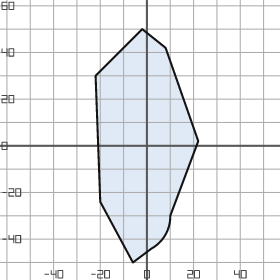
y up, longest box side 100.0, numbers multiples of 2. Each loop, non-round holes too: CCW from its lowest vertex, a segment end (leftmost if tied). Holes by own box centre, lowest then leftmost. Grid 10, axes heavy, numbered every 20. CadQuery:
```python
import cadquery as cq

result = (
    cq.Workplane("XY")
    .moveTo(-6.0, -50.0)
    .lineTo(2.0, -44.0)
    .threePointArc((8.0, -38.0), (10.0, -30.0))
    .lineTo(22.0, 2.0)
    .lineTo(8.0, 42.0)
    .lineTo(-2.0, 50.0)
    .lineTo(-22.0, 30.0)
    .lineTo(-20.0, -24.0)
    .close()
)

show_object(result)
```